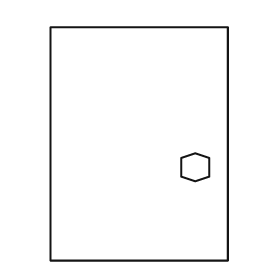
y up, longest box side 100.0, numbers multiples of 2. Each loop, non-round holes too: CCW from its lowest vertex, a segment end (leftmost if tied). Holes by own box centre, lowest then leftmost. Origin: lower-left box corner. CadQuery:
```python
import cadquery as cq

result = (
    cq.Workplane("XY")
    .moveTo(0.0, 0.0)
    .lineTo(76.0, 0.0)
    .lineTo(76.0, 100.0)
    .lineTo(0.0, 100.0)
    .close()
    .moveTo(62.0, 34.0)
    .lineTo(68.0, 36.0)
    .lineTo(68.0, 44.0)
    .lineTo(62.0, 46.0)
    .lineTo(56.0, 44.0)
    .lineTo(56.0, 36.0)
    .close()
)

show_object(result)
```